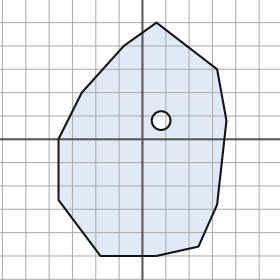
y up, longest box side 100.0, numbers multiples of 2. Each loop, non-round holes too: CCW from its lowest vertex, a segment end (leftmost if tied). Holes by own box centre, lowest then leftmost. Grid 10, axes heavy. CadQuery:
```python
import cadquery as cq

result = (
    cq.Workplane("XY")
    .moveTo(-18.0, -50.0)
    .lineTo(6.0, -50.0)
    .lineTo(24.0, -46.0)
    .lineTo(32.0, -28.0)
    .lineTo(36.0, 8.0)
    .lineTo(32.0, 30.0)
    .lineTo(6.0, 50.0)
    .lineTo(-8.0, 40.0)
    .lineTo(-26.0, 20.0)
    .lineTo(-36.0, 0.0)
    .lineTo(-36.0, -26.0)
    .close()
    .moveTo(8.0, 8.0)
    .circle(4.0)
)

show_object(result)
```